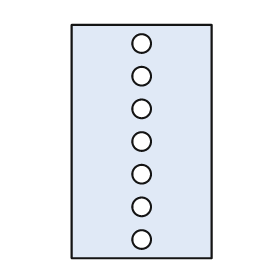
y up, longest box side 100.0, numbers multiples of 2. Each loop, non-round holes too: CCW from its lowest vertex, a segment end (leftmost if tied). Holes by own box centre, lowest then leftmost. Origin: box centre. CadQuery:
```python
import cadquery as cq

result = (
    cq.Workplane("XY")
    .moveTo(-30.0, -50.0)
    .lineTo(30.0, -50.0)
    .lineTo(30.0, 50.0)
    .lineTo(-30.0, 50.0)
    .close()
    .moveTo(0.0, -42.0)
    .circle(4.0)
    .moveTo(0.0, -28.0)
    .circle(4.0)
    .moveTo(0.0, -14.0)
    .circle(4.0)
    .moveTo(0.0, 0.0)
    .circle(4.0)
    .moveTo(0.0, 14.0)
    .circle(4.0)
    .moveTo(0.0, 28.0)
    .circle(4.0)
    .moveTo(0.0, 42.0)
    .circle(4.0)
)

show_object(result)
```